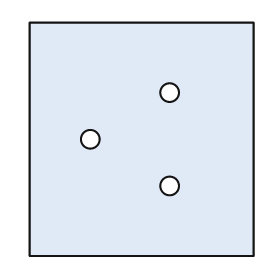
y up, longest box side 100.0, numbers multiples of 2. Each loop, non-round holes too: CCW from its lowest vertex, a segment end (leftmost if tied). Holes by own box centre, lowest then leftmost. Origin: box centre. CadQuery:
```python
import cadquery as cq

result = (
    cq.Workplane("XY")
    .moveTo(-48.0, -50.0)
    .lineTo(48.0, -50.0)
    .lineTo(48.0, 50.0)
    .lineTo(-48.0, 50.0)
    .close()
    .moveTo(12.0, -20.0)
    .circle(4.0)
    .moveTo(-22.0, 0.0)
    .circle(4.0)
    .moveTo(12.0, 20.0)
    .circle(4.0)
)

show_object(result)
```